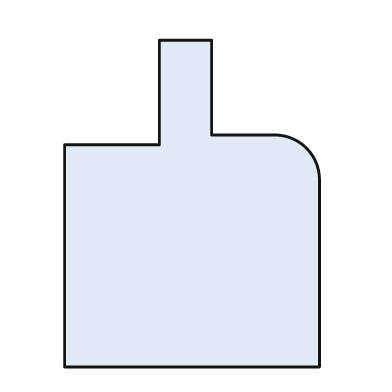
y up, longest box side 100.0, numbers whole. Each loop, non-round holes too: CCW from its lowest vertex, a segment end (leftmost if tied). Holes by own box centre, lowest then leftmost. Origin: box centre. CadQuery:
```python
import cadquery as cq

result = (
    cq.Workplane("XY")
    .moveTo(-39.0, -50.0)
    .lineTo(39.0, -50.0)
    .lineTo(39.0, 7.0)
    .threePointArc((35.0, 17.0), (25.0, 21.0))
    .lineTo(6.0, 21.0)
    .lineTo(6.0, 50.0)
    .lineTo(-10.0, 50.0)
    .lineTo(-10.0, 18.0)
    .lineTo(-39.0, 18.0)
    .close()
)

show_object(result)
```